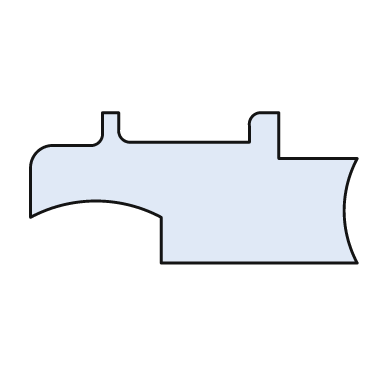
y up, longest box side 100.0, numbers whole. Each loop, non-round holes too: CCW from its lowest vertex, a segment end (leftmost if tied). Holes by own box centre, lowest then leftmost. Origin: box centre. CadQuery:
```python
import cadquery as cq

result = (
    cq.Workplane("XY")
    .moveTo(-10.0, -23.0)
    .lineTo(50.0, -23.0)
    .threePointArc((46.0, -7.0), (50.0, 9.0))
    .lineTo(26.0, 9.0)
    .lineTo(26.0, 23.0)
    .lineTo(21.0, 23.0)
    .threePointArc((18.0, 22.0), (17.0, 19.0))
    .lineTo(17.0, 14.0)
    .lineTo(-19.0, 14.0)
    .threePointArc((-22.0, 15.0), (-23.0, 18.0))
    .lineTo(-23.0, 23.0)
    .lineTo(-28.0, 23.0)
    .lineTo(-28.0, 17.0)
    .threePointArc((-29.0, 14.0), (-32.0, 13.0))
    .lineTo(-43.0, 13.0)
    .threePointArc((-48.0, 11.0), (-50.0, 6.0))
    .lineTo(-50.0, -9.0)
    .threePointArc((-30.0, -4.0), (-10.0, -9.0))
    .close()
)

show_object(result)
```